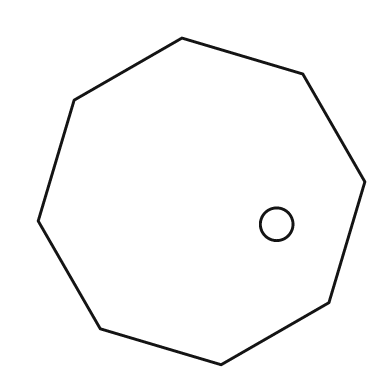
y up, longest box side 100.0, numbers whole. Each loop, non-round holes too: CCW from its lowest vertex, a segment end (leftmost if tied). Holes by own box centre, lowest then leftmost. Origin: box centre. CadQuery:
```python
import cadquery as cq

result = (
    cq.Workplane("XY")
    .moveTo(6.0, -50.0)
    .lineTo(39.0, -31.0)
    .lineTo(50.0, 6.0)
    .lineTo(31.0, 39.0)
    .lineTo(-6.0, 50.0)
    .lineTo(-39.0, 31.0)
    .lineTo(-50.0, -6.0)
    .lineTo(-31.0, -39.0)
    .close()
    .moveTo(23.0, -7.0)
    .circle(5.0)
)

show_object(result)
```